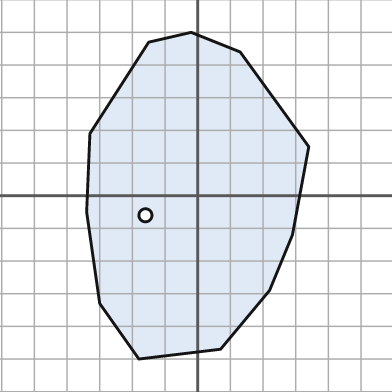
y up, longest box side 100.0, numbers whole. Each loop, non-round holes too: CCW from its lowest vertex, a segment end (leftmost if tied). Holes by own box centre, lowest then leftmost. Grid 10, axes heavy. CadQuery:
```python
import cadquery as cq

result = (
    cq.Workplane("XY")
    .moveTo(-18.0, -50.0)
    .lineTo(7.0, -47.0)
    .lineTo(22.0, -29.0)
    .lineTo(29.0, -12.0)
    .lineTo(34.0, 15.0)
    .lineTo(13.0, 44.0)
    .lineTo(-2.0, 50.0)
    .lineTo(-15.0, 47.0)
    .lineTo(-33.0, 19.0)
    .lineTo(-34.0, -5.0)
    .lineTo(-30.0, -33.0)
    .close()
    .moveTo(-16.0, -6.0)
    .circle(2.0)
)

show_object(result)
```